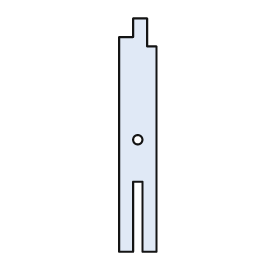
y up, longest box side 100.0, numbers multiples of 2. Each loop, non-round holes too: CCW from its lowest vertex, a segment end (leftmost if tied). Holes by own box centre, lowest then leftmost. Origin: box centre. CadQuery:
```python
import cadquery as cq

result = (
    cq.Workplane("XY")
    .moveTo(-8.0, -50.0)
    .lineTo(-2.0, -50.0)
    .lineTo(-2.0, -20.0)
    .lineTo(2.0, -20.0)
    .lineTo(2.0, -50.0)
    .lineTo(8.0, -50.0)
    .lineTo(8.0, 38.0)
    .lineTo(4.0, 38.0)
    .lineTo(4.0, 50.0)
    .lineTo(-2.0, 50.0)
    .lineTo(-2.0, 42.0)
    .lineTo(-8.0, 42.0)
    .close()
    .moveTo(0.0, -2.0)
    .circle(2.0)
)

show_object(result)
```